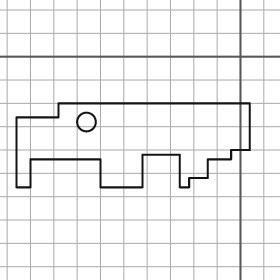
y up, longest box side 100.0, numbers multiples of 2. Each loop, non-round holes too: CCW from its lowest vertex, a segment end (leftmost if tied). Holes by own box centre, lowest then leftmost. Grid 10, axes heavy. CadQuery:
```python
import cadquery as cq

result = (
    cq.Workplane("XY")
    .moveTo(-96.0, -56.0)
    .lineTo(-90.0, -56.0)
    .lineTo(-90.0, -44.0)
    .lineTo(-60.0, -44.0)
    .lineTo(-60.0, -56.0)
    .lineTo(-42.0, -56.0)
    .lineTo(-42.0, -42.0)
    .lineTo(-26.0, -42.0)
    .lineTo(-26.0, -56.0)
    .lineTo(-22.0, -56.0)
    .lineTo(-22.0, -52.0)
    .lineTo(-14.0, -52.0)
    .lineTo(-14.0, -44.0)
    .lineTo(-4.0, -44.0)
    .lineTo(-4.0, -40.0)
    .lineTo(4.0, -40.0)
    .lineTo(4.0, -20.0)
    .lineTo(-78.0, -20.0)
    .lineTo(-78.0, -26.0)
    .lineTo(-96.0, -26.0)
    .close()
    .moveTo(-66.0, -28.0)
    .circle(4.0)
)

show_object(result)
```